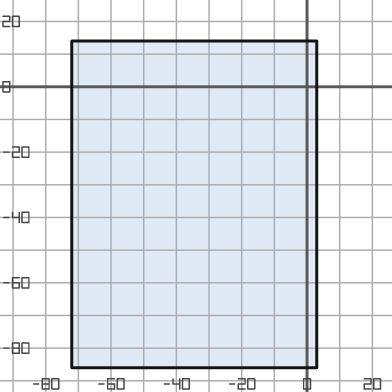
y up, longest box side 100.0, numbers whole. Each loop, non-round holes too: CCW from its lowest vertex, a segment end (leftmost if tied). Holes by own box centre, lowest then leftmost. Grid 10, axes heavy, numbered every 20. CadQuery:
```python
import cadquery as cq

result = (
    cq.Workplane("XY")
    .moveTo(-72.0, -86.0)
    .lineTo(3.0, -86.0)
    .lineTo(3.0, 14.0)
    .lineTo(-72.0, 14.0)
    .close()
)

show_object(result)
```